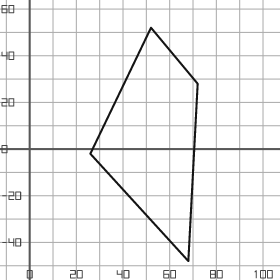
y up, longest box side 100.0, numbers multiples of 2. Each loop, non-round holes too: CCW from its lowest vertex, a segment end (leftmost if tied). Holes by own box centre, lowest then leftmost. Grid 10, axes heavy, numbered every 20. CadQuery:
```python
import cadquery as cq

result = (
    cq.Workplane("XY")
    .moveTo(68.0, -48.0)
    .lineTo(72.0, 28.0)
    .lineTo(52.0, 52.0)
    .lineTo(26.0, -2.0)
    .close()
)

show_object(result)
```